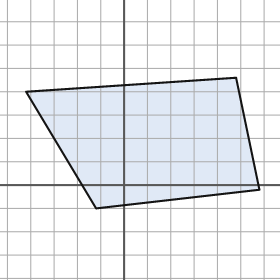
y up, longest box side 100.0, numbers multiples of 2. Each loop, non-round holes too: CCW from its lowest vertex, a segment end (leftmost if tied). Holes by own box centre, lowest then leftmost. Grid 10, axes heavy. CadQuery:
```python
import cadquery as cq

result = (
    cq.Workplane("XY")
    .moveTo(-12.0, -10.0)
    .lineTo(58.0, -2.0)
    .lineTo(48.0, 46.0)
    .lineTo(-42.0, 40.0)
    .close()
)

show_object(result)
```